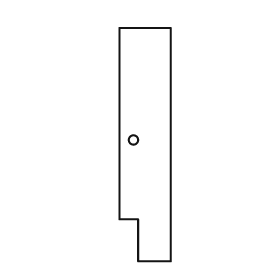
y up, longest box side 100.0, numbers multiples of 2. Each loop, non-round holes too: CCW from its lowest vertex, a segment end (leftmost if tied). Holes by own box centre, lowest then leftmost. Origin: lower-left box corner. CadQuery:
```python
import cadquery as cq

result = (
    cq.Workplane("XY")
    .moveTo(8.0, 0.0)
    .lineTo(22.0, 0.0)
    .lineTo(22.0, 100.0)
    .lineTo(0.0, 100.0)
    .lineTo(0.0, 18.0)
    .lineTo(8.0, 18.0)
    .close()
    .moveTo(6.0, 52.0)
    .circle(2.0)
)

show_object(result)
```